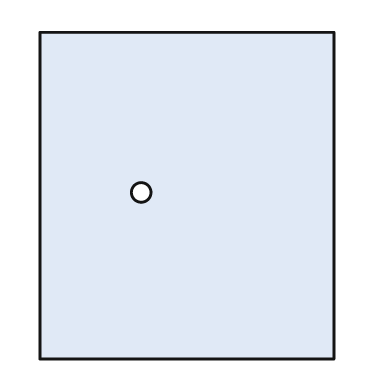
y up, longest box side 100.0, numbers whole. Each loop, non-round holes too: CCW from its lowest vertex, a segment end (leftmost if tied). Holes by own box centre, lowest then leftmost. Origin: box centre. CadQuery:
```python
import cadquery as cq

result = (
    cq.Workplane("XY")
    .moveTo(-45.0, -50.0)
    .lineTo(45.0, -50.0)
    .lineTo(45.0, 50.0)
    .lineTo(-45.0, 50.0)
    .close()
    .moveTo(-14.0, 1.0)
    .circle(3.0)
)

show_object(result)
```